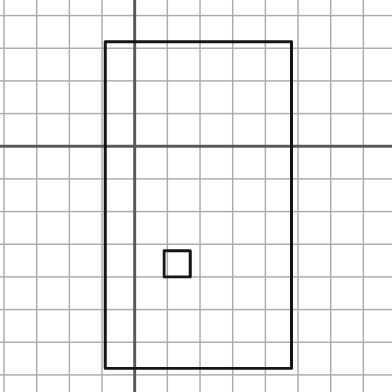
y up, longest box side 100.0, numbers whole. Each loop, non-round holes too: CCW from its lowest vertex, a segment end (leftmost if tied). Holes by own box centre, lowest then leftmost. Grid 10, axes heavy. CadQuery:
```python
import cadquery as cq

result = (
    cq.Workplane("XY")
    .moveTo(-9.0, -68.0)
    .lineTo(48.0, -68.0)
    .lineTo(48.0, 32.0)
    .lineTo(-9.0, 32.0)
    .close()
    .moveTo(9.0, -40.0)
    .lineTo(17.0, -40.0)
    .lineTo(17.0, -32.0)
    .lineTo(9.0, -32.0)
    .close()
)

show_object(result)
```